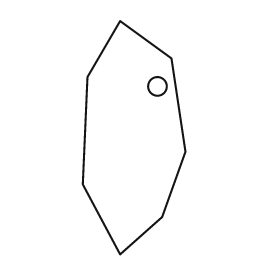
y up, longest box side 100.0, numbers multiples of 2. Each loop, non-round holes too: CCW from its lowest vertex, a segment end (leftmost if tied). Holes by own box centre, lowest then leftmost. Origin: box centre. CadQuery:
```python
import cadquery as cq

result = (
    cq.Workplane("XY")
    .moveTo(-6.0, -50.0)
    .lineTo(12.0, -34.0)
    .lineTo(22.0, -6.0)
    .lineTo(16.0, 34.0)
    .lineTo(-6.0, 50.0)
    .lineTo(-20.0, 26.0)
    .lineTo(-22.0, -20.0)
    .close()
    .moveTo(10.0, 22.0)
    .circle(4.0)
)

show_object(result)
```